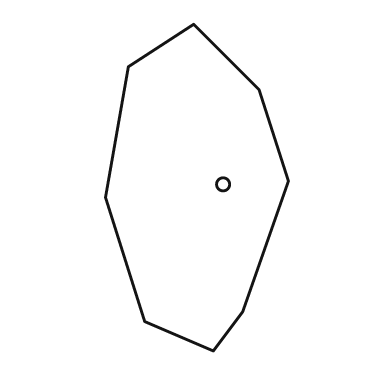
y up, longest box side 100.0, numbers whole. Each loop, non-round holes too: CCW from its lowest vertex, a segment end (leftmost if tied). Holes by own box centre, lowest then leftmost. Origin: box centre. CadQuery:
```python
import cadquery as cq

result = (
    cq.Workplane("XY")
    .moveTo(5.0, -50.0)
    .lineTo(14.0, -38.0)
    .lineTo(28.0, 2.0)
    .lineTo(19.0, 30.0)
    .lineTo(-1.0, 50.0)
    .lineTo(-21.0, 37.0)
    .lineTo(-28.0, -3.0)
    .lineTo(-16.0, -41.0)
    .close()
    .moveTo(8.0, 1.0)
    .circle(2.0)
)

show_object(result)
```